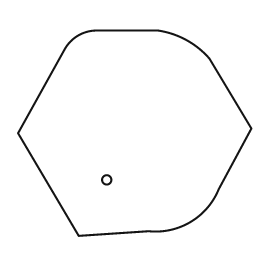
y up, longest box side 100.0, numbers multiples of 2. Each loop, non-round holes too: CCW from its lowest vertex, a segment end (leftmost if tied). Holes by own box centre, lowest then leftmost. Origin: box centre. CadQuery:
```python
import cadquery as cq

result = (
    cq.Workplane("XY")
    .moveTo(-24.0, -44.0)
    .lineTo(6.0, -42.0)
    .threePointArc((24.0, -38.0), (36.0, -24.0))
    .lineTo(50.0, 2.0)
    .lineTo(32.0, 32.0)
    .threePointArc((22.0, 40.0), (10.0, 44.0))
    .lineTo(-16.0, 44.0)
    .threePointArc((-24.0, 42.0), (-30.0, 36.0))
    .lineTo(-50.0, 0.0)
    .close()
    .moveTo(-12.0, -20.0)
    .circle(2.0)
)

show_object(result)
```